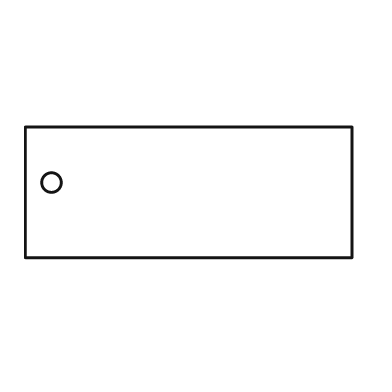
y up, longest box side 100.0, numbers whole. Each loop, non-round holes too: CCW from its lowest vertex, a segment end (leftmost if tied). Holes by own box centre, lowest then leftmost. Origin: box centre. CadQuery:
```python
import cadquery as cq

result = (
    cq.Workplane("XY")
    .moveTo(-50.0, -20.0)
    .lineTo(50.0, -20.0)
    .lineTo(50.0, 20.0)
    .lineTo(-50.0, 20.0)
    .close()
    .moveTo(-42.0, 3.0)
    .circle(3.0)
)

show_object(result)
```